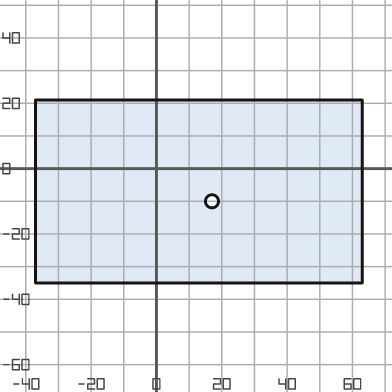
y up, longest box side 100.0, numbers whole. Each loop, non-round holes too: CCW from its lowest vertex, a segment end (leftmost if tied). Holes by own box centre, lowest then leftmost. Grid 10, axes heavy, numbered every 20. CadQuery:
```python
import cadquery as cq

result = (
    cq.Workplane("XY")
    .moveTo(-37.0, -35.0)
    .lineTo(63.0, -35.0)
    .lineTo(63.0, 21.0)
    .lineTo(-37.0, 21.0)
    .close()
    .moveTo(17.0, -10.0)
    .circle(2.0)
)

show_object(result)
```